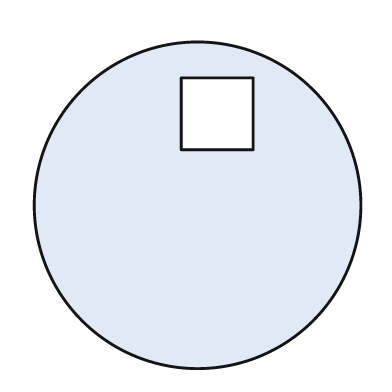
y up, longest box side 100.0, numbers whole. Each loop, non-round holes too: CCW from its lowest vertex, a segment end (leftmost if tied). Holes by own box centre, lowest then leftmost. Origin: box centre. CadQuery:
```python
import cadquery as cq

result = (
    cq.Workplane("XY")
    .moveTo(0.0, 0.0)
    .circle(50.0)
    .moveTo(-5.0, 17.0)
    .lineTo(17.0, 17.0)
    .lineTo(17.0, 39.0)
    .lineTo(-5.0, 39.0)
    .close()
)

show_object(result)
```